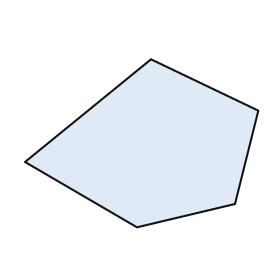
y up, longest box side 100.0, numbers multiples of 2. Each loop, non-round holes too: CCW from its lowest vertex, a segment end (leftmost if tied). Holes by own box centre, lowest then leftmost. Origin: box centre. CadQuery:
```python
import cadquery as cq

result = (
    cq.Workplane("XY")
    .moveTo(-2.0, -36.0)
    .lineTo(40.0, -26.0)
    .lineTo(50.0, 14.0)
    .lineTo(4.0, 36.0)
    .lineTo(-50.0, -8.0)
    .close()
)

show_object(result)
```